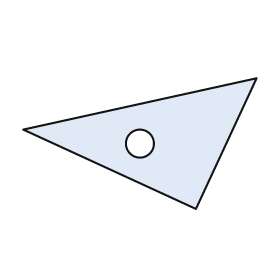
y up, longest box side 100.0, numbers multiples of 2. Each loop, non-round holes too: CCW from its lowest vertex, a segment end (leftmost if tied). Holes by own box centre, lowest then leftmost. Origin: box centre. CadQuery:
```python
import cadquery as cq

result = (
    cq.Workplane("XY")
    .moveTo(24.0, -28.0)
    .lineTo(50.0, 28.0)
    .lineTo(-50.0, 6.0)
    .close()
    .moveTo(0.0, 0.0)
    .circle(6.0)
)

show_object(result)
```